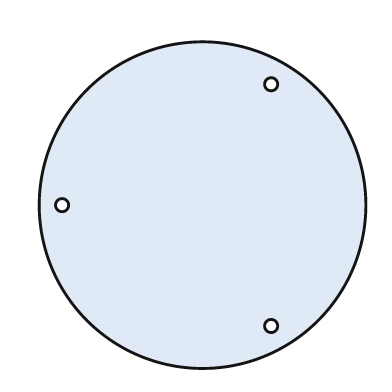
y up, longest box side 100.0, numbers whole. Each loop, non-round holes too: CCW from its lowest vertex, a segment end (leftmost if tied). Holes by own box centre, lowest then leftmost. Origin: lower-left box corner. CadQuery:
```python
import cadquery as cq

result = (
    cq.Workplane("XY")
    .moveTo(50.0, 50.0)
    .circle(50.0)
    .moveTo(71.0, 13.0)
    .circle(2.0)
    .moveTo(7.0, 50.0)
    .circle(2.0)
    .moveTo(71.0, 87.0)
    .circle(2.0)
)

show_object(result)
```